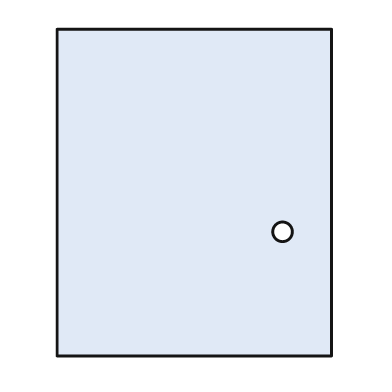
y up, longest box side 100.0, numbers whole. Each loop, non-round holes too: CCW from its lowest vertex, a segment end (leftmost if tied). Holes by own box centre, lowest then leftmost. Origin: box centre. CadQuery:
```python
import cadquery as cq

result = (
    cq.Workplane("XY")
    .moveTo(-42.0, -50.0)
    .lineTo(42.0, -50.0)
    .lineTo(42.0, 50.0)
    .lineTo(-42.0, 50.0)
    .close()
    .moveTo(27.0, -12.0)
    .circle(3.0)
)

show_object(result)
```